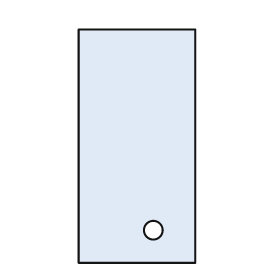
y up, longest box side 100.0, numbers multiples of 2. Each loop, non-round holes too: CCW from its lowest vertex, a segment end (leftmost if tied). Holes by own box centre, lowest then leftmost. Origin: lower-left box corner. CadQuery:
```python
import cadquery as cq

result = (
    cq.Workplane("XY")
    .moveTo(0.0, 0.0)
    .lineTo(50.0, 0.0)
    .lineTo(50.0, 100.0)
    .lineTo(0.0, 100.0)
    .close()
    .moveTo(32.0, 14.0)
    .circle(4.0)
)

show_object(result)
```